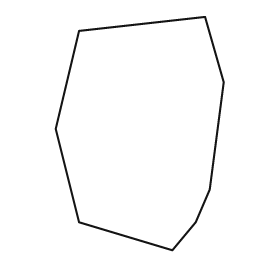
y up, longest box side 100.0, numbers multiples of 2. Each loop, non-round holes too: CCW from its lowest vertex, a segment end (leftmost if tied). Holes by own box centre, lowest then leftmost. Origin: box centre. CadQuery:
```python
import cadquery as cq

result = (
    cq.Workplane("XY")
    .moveTo(14.0, -50.0)
    .lineTo(24.0, -38.0)
    .lineTo(30.0, -24.0)
    .lineTo(36.0, 22.0)
    .lineTo(28.0, 50.0)
    .lineTo(-26.0, 44.0)
    .lineTo(-36.0, 2.0)
    .lineTo(-26.0, -38.0)
    .close()
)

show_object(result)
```